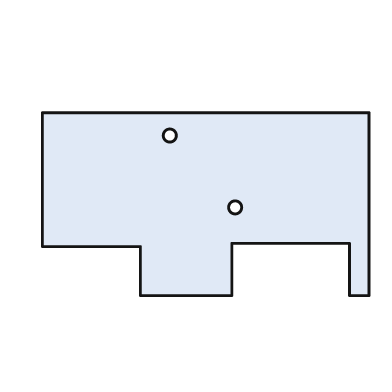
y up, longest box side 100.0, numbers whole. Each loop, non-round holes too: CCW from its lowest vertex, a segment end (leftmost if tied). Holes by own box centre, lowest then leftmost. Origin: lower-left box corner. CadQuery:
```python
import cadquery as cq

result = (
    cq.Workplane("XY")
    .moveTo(30.0, 0.0)
    .lineTo(58.0, 0.0)
    .lineTo(58.0, 16.0)
    .lineTo(94.0, 16.0)
    .lineTo(94.0, 0.0)
    .lineTo(100.0, 0.0)
    .lineTo(100.0, 56.0)
    .lineTo(0.0, 56.0)
    .lineTo(0.0, 15.0)
    .lineTo(30.0, 15.0)
    .close()
    .moveTo(59.0, 27.0)
    .circle(2.0)
    .moveTo(39.0, 49.0)
    .circle(2.0)
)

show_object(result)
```